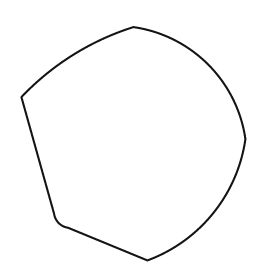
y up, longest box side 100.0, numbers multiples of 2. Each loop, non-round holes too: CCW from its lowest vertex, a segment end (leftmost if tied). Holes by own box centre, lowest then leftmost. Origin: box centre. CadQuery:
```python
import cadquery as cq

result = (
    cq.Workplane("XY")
    .moveTo(6.0, -50.0)
    .threePointArc((34.0, -30.0), (48.0, 2.0))
    .threePointArc((32.0, 34.0), (0.0, 50.0))
    .threePointArc((-26.0, 38.0), (-48.0, 20.0))
    .lineTo(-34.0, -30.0)
    .threePointArc((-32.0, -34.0), (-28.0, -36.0))
    .close()
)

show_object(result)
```